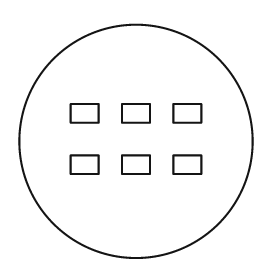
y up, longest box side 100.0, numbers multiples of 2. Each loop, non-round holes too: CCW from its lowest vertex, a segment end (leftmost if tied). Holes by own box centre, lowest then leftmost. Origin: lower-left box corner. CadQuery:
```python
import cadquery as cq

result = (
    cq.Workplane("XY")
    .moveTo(50.0, 50.0)
    .circle(50.0)
    .moveTo(22.0, 36.0)
    .lineTo(34.0, 36.0)
    .lineTo(34.0, 44.0)
    .lineTo(22.0, 44.0)
    .close()
    .moveTo(44.0, 36.0)
    .lineTo(56.0, 36.0)
    .lineTo(56.0, 44.0)
    .lineTo(44.0, 44.0)
    .close()
    .moveTo(66.0, 36.0)
    .lineTo(78.0, 36.0)
    .lineTo(78.0, 44.0)
    .lineTo(66.0, 44.0)
    .close()
    .moveTo(22.0, 58.0)
    .lineTo(34.0, 58.0)
    .lineTo(34.0, 66.0)
    .lineTo(22.0, 66.0)
    .close()
    .moveTo(44.0, 58.0)
    .lineTo(56.0, 58.0)
    .lineTo(56.0, 66.0)
    .lineTo(44.0, 66.0)
    .close()
    .moveTo(66.0, 58.0)
    .lineTo(78.0, 58.0)
    .lineTo(78.0, 66.0)
    .lineTo(66.0, 66.0)
    .close()
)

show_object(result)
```